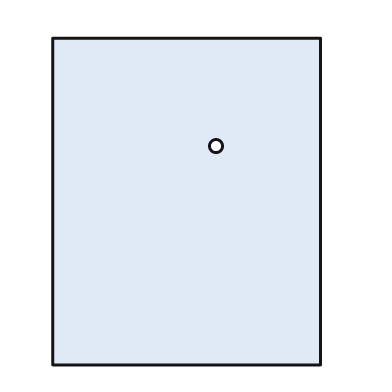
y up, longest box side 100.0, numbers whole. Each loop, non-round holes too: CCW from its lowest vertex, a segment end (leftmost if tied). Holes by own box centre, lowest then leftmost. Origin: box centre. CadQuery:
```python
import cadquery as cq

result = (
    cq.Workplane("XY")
    .moveTo(-41.0, -50.0)
    .lineTo(41.0, -50.0)
    .lineTo(41.0, 50.0)
    .lineTo(-41.0, 50.0)
    .close()
    .moveTo(9.0, 17.0)
    .circle(2.0)
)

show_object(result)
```